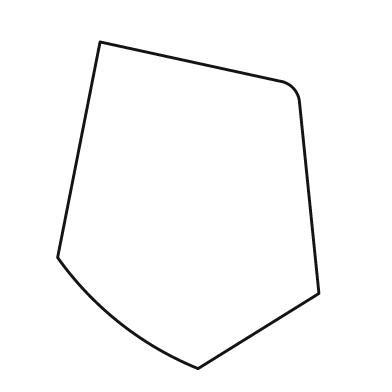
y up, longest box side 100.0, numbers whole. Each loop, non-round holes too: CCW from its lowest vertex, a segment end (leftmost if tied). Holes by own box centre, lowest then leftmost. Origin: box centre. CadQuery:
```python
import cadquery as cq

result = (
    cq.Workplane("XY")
    .moveTo(3.0, -50.0)
    .lineTo(40.0, -27.0)
    .lineTo(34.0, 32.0)
    .threePointArc((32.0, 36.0), (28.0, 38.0))
    .lineTo(-27.0, 50.0)
    .lineTo(-40.0, -16.0)
    .threePointArc((-21.0, -36.0), (3.0, -50.0))
    .close()
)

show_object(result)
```